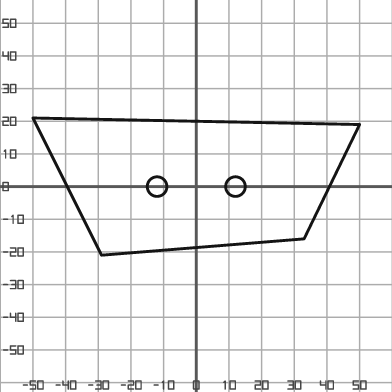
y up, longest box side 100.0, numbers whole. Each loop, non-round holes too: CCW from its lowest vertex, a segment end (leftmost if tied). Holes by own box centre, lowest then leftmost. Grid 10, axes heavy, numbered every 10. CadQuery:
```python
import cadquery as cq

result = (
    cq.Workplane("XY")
    .moveTo(-29.0, -21.0)
    .lineTo(33.0, -16.0)
    .lineTo(50.0, 19.0)
    .lineTo(-50.0, 21.0)
    .close()
    .moveTo(-12.0, 0.0)
    .circle(3.0)
    .moveTo(12.0, 0.0)
    .circle(3.0)
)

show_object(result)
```